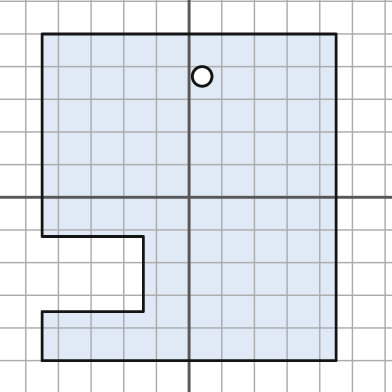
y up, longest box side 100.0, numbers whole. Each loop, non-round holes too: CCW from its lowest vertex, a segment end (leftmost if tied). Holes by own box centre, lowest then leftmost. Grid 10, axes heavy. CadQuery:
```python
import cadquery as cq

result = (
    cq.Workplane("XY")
    .moveTo(-45.0, -50.0)
    .lineTo(45.0, -50.0)
    .lineTo(45.0, 50.0)
    .lineTo(-45.0, 50.0)
    .lineTo(-45.0, -12.0)
    .lineTo(-14.0, -12.0)
    .lineTo(-14.0, -35.0)
    .lineTo(-45.0, -35.0)
    .close()
    .moveTo(4.0, 37.0)
    .circle(3.0)
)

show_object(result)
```